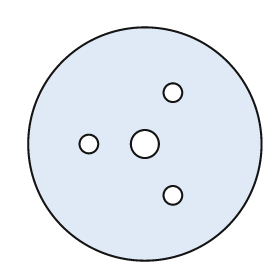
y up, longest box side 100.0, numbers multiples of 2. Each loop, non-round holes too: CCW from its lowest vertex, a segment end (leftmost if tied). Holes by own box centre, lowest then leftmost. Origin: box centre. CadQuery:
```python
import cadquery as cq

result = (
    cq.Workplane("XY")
    .moveTo(0.0, 0.0)
    .circle(50.0)
    .moveTo(12.0, -22.0)
    .circle(4.0)
    .moveTo(-24.0, 0.0)
    .circle(4.0)
    .moveTo(0.0, 0.0)
    .circle(6.0)
    .moveTo(12.0, 22.0)
    .circle(4.0)
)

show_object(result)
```